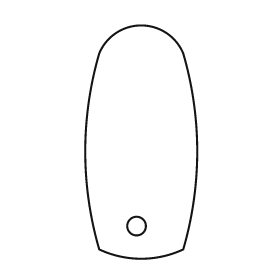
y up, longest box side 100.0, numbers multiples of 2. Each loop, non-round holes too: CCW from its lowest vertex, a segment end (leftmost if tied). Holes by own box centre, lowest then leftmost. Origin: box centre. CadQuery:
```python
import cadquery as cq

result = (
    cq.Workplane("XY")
    .moveTo(-18.0, -46.0)
    .threePointArc((0.0, -50.0), (18.0, -46.0))
    .threePointArc((24.0, -4.0), (18.0, 38.0))
    .threePointArc((0.0, 50.0), (-18.0, 38.0))
    .threePointArc((-24.0, -4.0), (-18.0, -46.0))
    .close()
    .moveTo(-2.0, -36.0)
    .circle(4.0)
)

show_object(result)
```